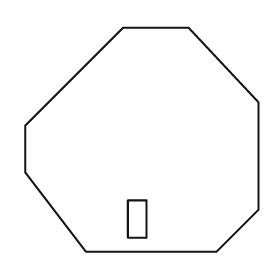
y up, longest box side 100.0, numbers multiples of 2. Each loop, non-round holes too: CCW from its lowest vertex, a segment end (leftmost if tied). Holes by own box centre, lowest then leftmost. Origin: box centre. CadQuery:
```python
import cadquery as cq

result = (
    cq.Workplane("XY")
    .moveTo(-24.0, -48.0)
    .lineTo(32.0, -48.0)
    .lineTo(50.0, -30.0)
    .lineTo(50.0, 16.0)
    .lineTo(20.0, 48.0)
    .lineTo(-8.0, 48.0)
    .lineTo(-50.0, 6.0)
    .lineTo(-50.0, -14.0)
    .close()
    .moveTo(-6.0, -42.0)
    .lineTo(2.0, -42.0)
    .lineTo(2.0, -26.0)
    .lineTo(-6.0, -26.0)
    .close()
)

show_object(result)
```